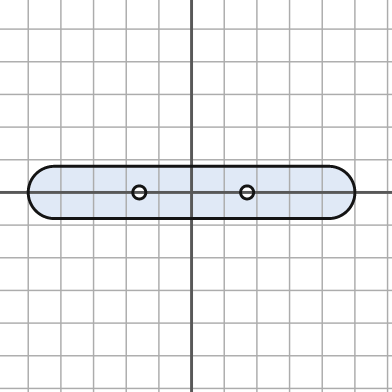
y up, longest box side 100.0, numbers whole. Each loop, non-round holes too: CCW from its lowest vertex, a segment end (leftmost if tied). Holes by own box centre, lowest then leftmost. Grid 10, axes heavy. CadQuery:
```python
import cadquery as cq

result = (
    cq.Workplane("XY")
    .moveTo(-42.0, -8.0)
    .lineTo(42.0, -8.0)
    .threePointArc((50.0, 0.0), (42.0, 8.0))
    .lineTo(-42.0, 8.0)
    .threePointArc((-50.0, 0.0), (-42.0, -8.0))
    .close()
    .moveTo(-16.0, 0.0)
    .circle(2.0)
    .moveTo(17.0, 0.0)
    .circle(2.0)
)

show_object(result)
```